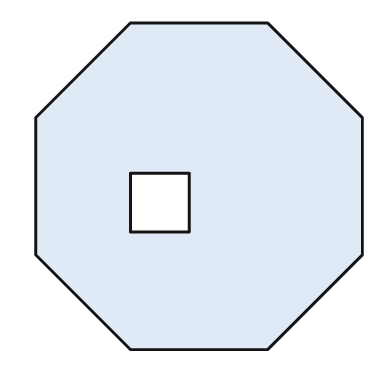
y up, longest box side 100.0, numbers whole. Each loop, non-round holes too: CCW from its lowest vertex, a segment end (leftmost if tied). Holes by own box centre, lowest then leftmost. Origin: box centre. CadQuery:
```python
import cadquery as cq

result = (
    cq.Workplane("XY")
    .moveTo(-21.0, -50.0)
    .lineTo(21.0, -50.0)
    .lineTo(50.0, -21.0)
    .lineTo(50.0, 21.0)
    .lineTo(21.0, 50.0)
    .lineTo(-21.0, 50.0)
    .lineTo(-50.0, 21.0)
    .lineTo(-50.0, -21.0)
    .close()
    .moveTo(-21.0, -14.0)
    .lineTo(-3.0, -14.0)
    .lineTo(-3.0, 4.0)
    .lineTo(-21.0, 4.0)
    .close()
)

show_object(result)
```